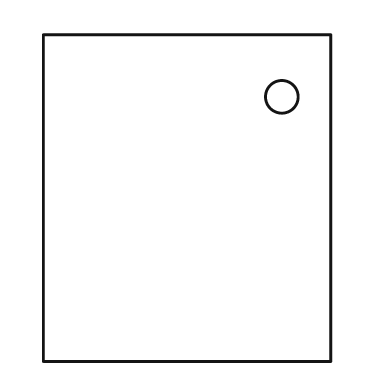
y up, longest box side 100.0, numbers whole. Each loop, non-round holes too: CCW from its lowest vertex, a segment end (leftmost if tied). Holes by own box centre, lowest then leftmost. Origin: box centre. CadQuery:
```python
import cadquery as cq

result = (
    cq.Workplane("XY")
    .moveTo(-44.0, -50.0)
    .lineTo(44.0, -50.0)
    .lineTo(44.0, 50.0)
    .lineTo(-44.0, 50.0)
    .close()
    .moveTo(29.0, 31.0)
    .circle(5.0)
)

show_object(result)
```